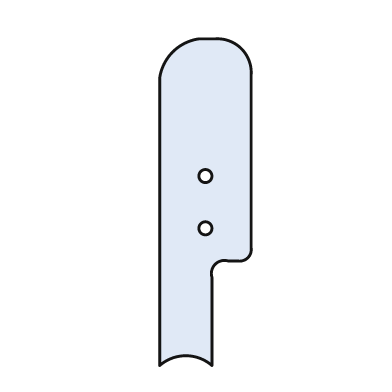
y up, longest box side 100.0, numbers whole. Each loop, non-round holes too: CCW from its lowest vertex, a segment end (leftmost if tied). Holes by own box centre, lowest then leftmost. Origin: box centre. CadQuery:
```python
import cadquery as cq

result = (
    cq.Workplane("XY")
    .moveTo(-14.0, -50.0)
    .threePointArc((-6.0, -47.0), (2.0, -50.0))
    .lineTo(2.0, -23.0)
    .threePointArc((3.0, -19.0), (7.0, -18.0))
    .lineTo(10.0, -18.0)
    .threePointArc((13.0, -17.0), (14.0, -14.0))
    .lineTo(14.0, 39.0)
    .threePointArc((11.0, 47.0), (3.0, 50.0))
    .lineTo(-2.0, 50.0)
    .threePointArc((-10.0, 46.0), (-14.0, 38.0))
    .close()
    .moveTo(0.0, -8.0)
    .circle(2.0)
    .moveTo(0.0, 8.0)
    .circle(2.0)
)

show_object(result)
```